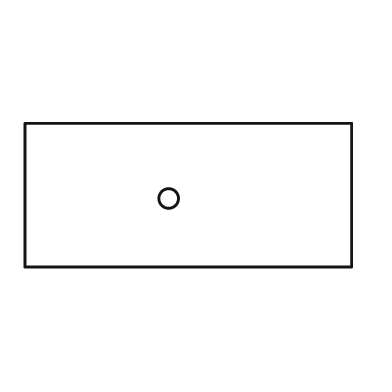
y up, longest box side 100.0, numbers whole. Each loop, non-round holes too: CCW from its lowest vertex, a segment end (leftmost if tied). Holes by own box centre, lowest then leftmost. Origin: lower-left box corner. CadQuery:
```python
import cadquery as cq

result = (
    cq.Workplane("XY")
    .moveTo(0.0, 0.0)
    .lineTo(100.0, 0.0)
    .lineTo(100.0, 44.0)
    .lineTo(0.0, 44.0)
    .close()
    .moveTo(44.0, 21.0)
    .circle(3.0)
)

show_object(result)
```